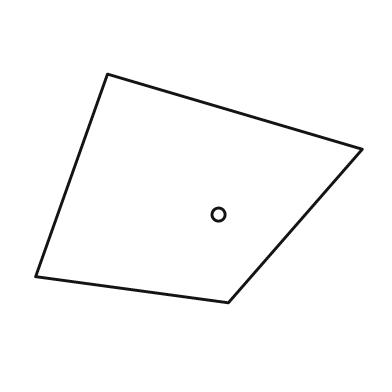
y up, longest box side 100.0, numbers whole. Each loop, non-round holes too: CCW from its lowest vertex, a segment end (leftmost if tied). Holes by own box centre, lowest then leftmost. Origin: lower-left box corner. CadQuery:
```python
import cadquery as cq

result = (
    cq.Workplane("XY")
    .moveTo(59.0, 0.0)
    .lineTo(100.0, 47.0)
    .lineTo(22.0, 70.0)
    .lineTo(0.0, 8.0)
    .close()
    .moveTo(56.0, 27.0)
    .circle(2.0)
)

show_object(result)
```